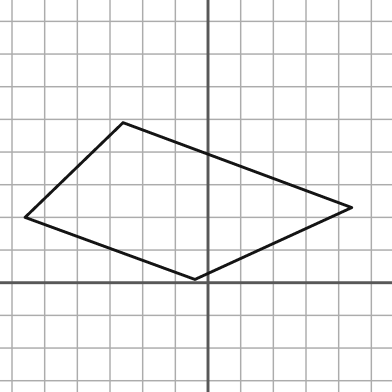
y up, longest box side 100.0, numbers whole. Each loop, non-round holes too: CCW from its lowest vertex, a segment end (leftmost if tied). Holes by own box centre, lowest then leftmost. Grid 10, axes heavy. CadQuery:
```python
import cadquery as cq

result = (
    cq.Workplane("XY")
    .moveTo(-4.0, 1.0)
    .lineTo(44.0, 23.0)
    .lineTo(-26.0, 49.0)
    .lineTo(-56.0, 20.0)
    .close()
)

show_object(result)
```